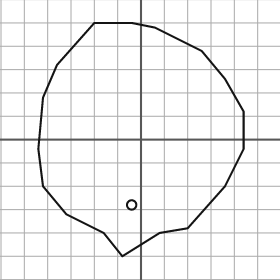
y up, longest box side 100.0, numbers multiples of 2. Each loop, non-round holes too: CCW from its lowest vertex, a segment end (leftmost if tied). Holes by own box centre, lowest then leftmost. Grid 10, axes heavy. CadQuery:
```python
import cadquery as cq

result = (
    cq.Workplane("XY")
    .moveTo(-8.0, -50.0)
    .lineTo(8.0, -40.0)
    .lineTo(20.0, -38.0)
    .lineTo(36.0, -20.0)
    .lineTo(44.0, -4.0)
    .lineTo(44.0, 12.0)
    .lineTo(36.0, 26.0)
    .lineTo(26.0, 38.0)
    .lineTo(6.0, 48.0)
    .lineTo(-4.0, 50.0)
    .lineTo(-20.0, 50.0)
    .lineTo(-36.0, 32.0)
    .lineTo(-42.0, 18.0)
    .lineTo(-44.0, -4.0)
    .lineTo(-42.0, -20.0)
    .lineTo(-32.0, -32.0)
    .lineTo(-16.0, -40.0)
    .close()
    .moveTo(-4.0, -28.0)
    .circle(2.0)
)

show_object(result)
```